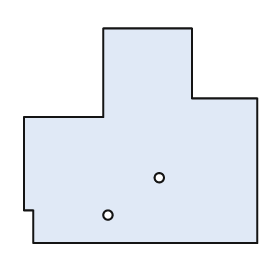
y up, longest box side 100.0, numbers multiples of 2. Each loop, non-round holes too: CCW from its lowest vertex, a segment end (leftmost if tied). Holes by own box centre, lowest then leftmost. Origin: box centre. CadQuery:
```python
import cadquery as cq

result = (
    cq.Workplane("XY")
    .moveTo(-46.0, -46.0)
    .lineTo(50.0, -46.0)
    .lineTo(50.0, 16.0)
    .lineTo(22.0, 16.0)
    .lineTo(22.0, 46.0)
    .lineTo(-16.0, 46.0)
    .lineTo(-16.0, 8.0)
    .lineTo(-50.0, 8.0)
    .lineTo(-50.0, -32.0)
    .lineTo(-46.0, -32.0)
    .close()
    .moveTo(-14.0, -34.0)
    .circle(2.0)
    .moveTo(8.0, -18.0)
    .circle(2.0)
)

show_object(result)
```